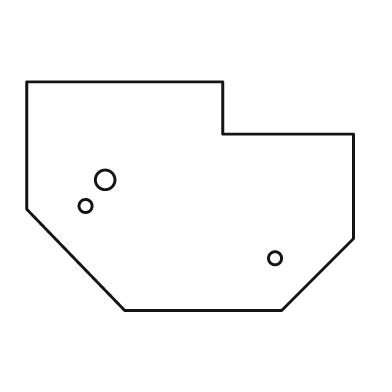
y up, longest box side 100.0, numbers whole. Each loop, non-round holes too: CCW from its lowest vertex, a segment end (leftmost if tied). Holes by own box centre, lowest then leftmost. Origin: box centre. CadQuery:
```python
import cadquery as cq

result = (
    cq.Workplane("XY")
    .moveTo(-20.0, -35.0)
    .lineTo(28.0, -35.0)
    .lineTo(50.0, -13.0)
    .lineTo(50.0, 19.0)
    .lineTo(10.0, 19.0)
    .lineTo(10.0, 35.0)
    .lineTo(-50.0, 35.0)
    .lineTo(-50.0, -4.0)
    .close()
    .moveTo(26.0, -19.0)
    .circle(2.0)
    .moveTo(-32.0, -3.0)
    .circle(2.0)
    .moveTo(-26.0, 5.0)
    .circle(3.0)
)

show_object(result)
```